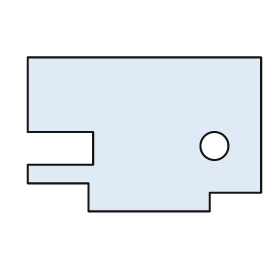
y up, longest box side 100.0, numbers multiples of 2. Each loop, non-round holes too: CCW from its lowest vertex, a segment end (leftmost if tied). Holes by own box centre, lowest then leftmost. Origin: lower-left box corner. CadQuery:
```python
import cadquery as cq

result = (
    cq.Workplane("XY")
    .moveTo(26.0, 0.0)
    .lineTo(78.0, 0.0)
    .lineTo(78.0, 8.0)
    .lineTo(100.0, 8.0)
    .lineTo(100.0, 66.0)
    .lineTo(0.0, 66.0)
    .lineTo(0.0, 34.0)
    .lineTo(28.0, 34.0)
    .lineTo(28.0, 20.0)
    .lineTo(0.0, 20.0)
    .lineTo(0.0, 12.0)
    .lineTo(26.0, 12.0)
    .close()
    .moveTo(80.0, 28.0)
    .circle(6.0)
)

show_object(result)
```